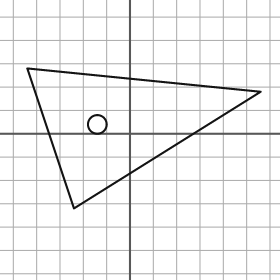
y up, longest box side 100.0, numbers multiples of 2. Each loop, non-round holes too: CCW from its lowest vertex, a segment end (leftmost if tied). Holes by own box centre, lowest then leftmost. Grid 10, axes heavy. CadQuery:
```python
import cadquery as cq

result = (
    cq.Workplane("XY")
    .moveTo(-24.0, -32.0)
    .lineTo(56.0, 18.0)
    .lineTo(-44.0, 28.0)
    .close()
    .moveTo(-14.0, 4.0)
    .circle(4.0)
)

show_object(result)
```